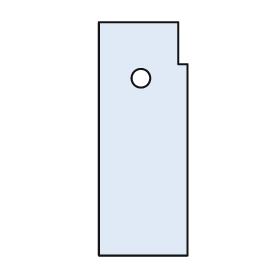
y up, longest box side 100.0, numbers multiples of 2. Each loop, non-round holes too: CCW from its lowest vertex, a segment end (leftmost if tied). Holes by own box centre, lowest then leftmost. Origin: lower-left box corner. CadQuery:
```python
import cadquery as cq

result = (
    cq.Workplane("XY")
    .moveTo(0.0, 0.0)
    .lineTo(38.0, 0.0)
    .lineTo(38.0, 82.0)
    .lineTo(34.0, 82.0)
    .lineTo(34.0, 100.0)
    .lineTo(0.0, 100.0)
    .close()
    .moveTo(18.0, 76.0)
    .circle(4.0)
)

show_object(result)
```